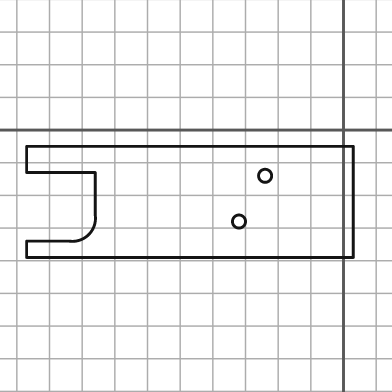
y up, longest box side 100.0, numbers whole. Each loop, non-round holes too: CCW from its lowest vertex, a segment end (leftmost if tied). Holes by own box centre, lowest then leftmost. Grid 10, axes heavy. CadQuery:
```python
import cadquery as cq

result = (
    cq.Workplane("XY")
    .moveTo(-97.0, -39.0)
    .lineTo(3.0, -39.0)
    .lineTo(3.0, -5.0)
    .lineTo(-97.0, -5.0)
    .lineTo(-97.0, -13.0)
    .lineTo(-76.0, -13.0)
    .lineTo(-76.0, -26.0)
    .threePointArc((-78.0, -32.0), (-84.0, -34.0))
    .lineTo(-97.0, -34.0)
    .close()
    .moveTo(-32.0, -28.0)
    .circle(2.0)
    .moveTo(-24.0, -14.0)
    .circle(2.0)
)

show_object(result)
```